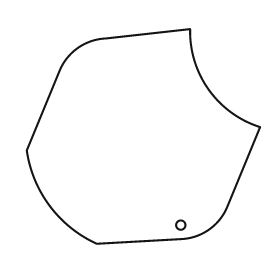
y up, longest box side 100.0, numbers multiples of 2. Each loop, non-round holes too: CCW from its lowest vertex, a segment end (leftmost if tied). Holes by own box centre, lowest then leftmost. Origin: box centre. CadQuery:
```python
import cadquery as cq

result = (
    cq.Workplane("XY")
    .moveTo(-20.0, -46.0)
    .lineTo(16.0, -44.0)
    .threePointArc((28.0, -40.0), (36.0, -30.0))
    .lineTo(50.0, 4.0)
    .threePointArc((28.0, 20.0), (20.0, 46.0))
    .lineTo(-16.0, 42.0)
    .threePointArc((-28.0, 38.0), (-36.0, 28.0))
    .lineTo(-50.0, -6.0)
    .threePointArc((-40.0, -30.0), (-20.0, -46.0))
    .close()
    .moveTo(16.0, -38.0)
    .circle(2.0)
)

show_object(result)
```